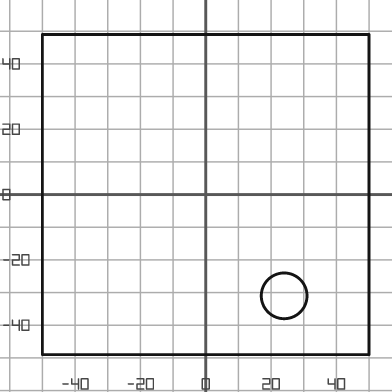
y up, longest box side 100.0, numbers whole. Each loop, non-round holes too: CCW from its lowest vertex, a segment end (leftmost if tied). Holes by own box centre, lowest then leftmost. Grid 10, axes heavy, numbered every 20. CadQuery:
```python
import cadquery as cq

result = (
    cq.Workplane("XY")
    .moveTo(-50.0, -49.0)
    .lineTo(50.0, -49.0)
    .lineTo(50.0, 49.0)
    .lineTo(-50.0, 49.0)
    .close()
    .moveTo(24.0, -31.0)
    .circle(7.0)
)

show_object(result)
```